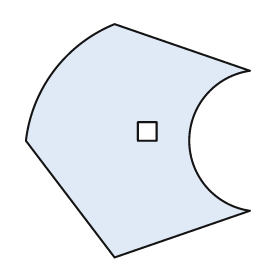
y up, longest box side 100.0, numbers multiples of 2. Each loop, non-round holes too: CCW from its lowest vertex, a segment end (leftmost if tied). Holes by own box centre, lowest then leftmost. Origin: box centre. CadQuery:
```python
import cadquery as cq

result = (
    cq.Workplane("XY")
    .moveTo(-10.0, -50.0)
    .lineTo(48.0, -30.0)
    .threePointArc((22.0, 0.0), (48.0, 30.0))
    .lineTo(-10.0, 50.0)
    .threePointArc((-36.0, 30.0), (-48.0, 0.0))
    .close()
    .moveTo(0.0, 0.0)
    .lineTo(8.0, 0.0)
    .lineTo(8.0, 8.0)
    .lineTo(0.0, 8.0)
    .close()
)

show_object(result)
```